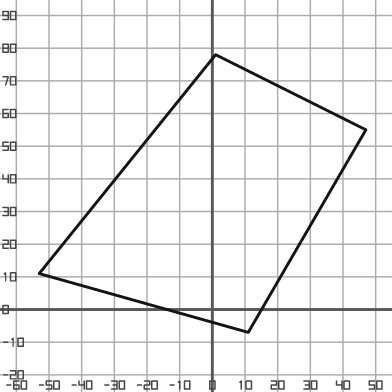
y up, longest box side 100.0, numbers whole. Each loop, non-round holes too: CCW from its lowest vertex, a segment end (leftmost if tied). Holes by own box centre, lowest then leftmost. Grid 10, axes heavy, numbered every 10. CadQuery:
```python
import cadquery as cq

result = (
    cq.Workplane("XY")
    .moveTo(11.0, -7.0)
    .lineTo(47.0, 55.0)
    .lineTo(1.0, 78.0)
    .lineTo(-53.0, 11.0)
    .close()
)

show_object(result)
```